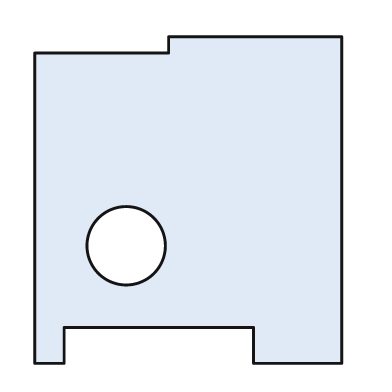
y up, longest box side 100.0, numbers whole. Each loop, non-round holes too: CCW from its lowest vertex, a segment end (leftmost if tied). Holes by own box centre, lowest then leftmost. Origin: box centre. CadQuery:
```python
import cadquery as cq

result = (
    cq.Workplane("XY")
    .moveTo(-47.0, -50.0)
    .lineTo(-38.0, -50.0)
    .lineTo(-38.0, -39.0)
    .lineTo(20.0, -39.0)
    .lineTo(20.0, -50.0)
    .lineTo(47.0, -50.0)
    .lineTo(47.0, 50.0)
    .lineTo(-6.0, 50.0)
    .lineTo(-6.0, 45.0)
    .lineTo(-47.0, 45.0)
    .close()
    .moveTo(-19.0, -14.0)
    .circle(12.0)
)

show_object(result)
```